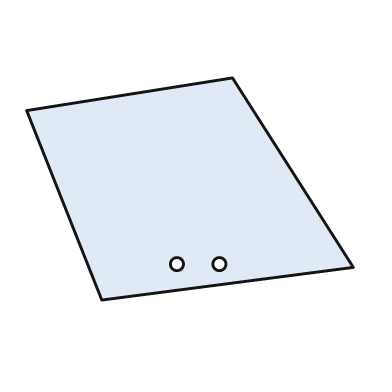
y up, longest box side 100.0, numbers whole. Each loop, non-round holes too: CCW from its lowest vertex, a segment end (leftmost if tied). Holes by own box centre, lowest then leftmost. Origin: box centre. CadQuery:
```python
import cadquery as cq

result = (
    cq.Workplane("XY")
    .moveTo(-27.0, -34.0)
    .lineTo(50.0, -24.0)
    .lineTo(13.0, 34.0)
    .lineTo(-50.0, 24.0)
    .close()
    .moveTo(-4.0, -23.0)
    .circle(2.0)
    .moveTo(9.0, -23.0)
    .circle(2.0)
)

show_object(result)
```